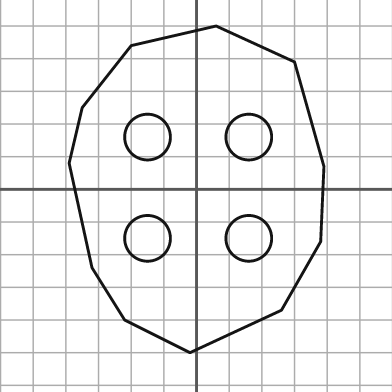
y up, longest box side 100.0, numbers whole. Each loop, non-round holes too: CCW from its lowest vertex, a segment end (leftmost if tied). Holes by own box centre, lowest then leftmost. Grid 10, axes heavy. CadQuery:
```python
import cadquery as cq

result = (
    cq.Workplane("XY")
    .moveTo(-2.0, -50.0)
    .lineTo(26.0, -37.0)
    .lineTo(38.0, -16.0)
    .lineTo(39.0, 7.0)
    .lineTo(30.0, 39.0)
    .lineTo(6.0, 50.0)
    .lineTo(-20.0, 44.0)
    .lineTo(-35.0, 25.0)
    .lineTo(-39.0, 8.0)
    .lineTo(-32.0, -24.0)
    .lineTo(-22.0, -40.0)
    .close()
    .moveTo(-15.0, -15.0)
    .circle(7.0)
    .moveTo(16.0, -15.0)
    .circle(7.0)
    .moveTo(-15.0, 16.0)
    .circle(7.0)
    .moveTo(16.0, 16.0)
    .circle(7.0)
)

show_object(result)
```